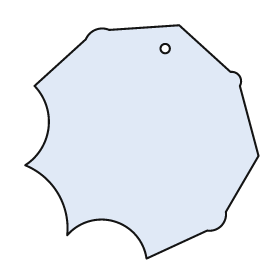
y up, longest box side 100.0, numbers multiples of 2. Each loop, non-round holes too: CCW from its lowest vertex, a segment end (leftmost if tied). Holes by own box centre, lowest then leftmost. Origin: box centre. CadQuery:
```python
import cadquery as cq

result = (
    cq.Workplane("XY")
    .moveTo(2.0, -50.0)
    .lineTo(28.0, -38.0)
    .threePointArc((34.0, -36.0), (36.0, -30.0))
    .lineTo(50.0, -6.0)
    .lineTo(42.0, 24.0)
    .threePointArc((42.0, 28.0), (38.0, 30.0))
    .lineTo(16.0, 50.0)
    .lineTo(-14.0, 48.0)
    .threePointArc((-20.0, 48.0), (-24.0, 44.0))
    .lineTo(-46.0, 24.0)
    .threePointArc((-40.0, 6.0), (-50.0, -10.0))
    .threePointArc((-36.0, -22.0), (-32.0, -40.0))
    .threePointArc((-12.0, -34.0), (2.0, -50.0))
    .close()
    .moveTo(10.0, 40.0)
    .circle(2.0)
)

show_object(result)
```